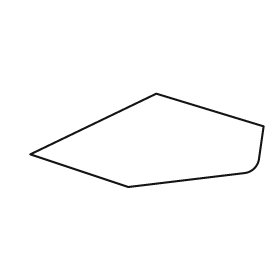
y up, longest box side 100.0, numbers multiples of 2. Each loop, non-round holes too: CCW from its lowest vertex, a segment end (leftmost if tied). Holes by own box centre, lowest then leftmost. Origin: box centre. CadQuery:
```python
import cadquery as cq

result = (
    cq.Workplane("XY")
    .moveTo(-8.0, -20.0)
    .lineTo(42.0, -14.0)
    .threePointArc((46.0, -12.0), (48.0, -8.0))
    .lineTo(50.0, 6.0)
    .lineTo(4.0, 20.0)
    .lineTo(-50.0, -6.0)
    .close()
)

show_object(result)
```